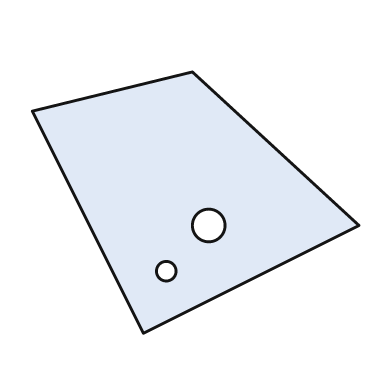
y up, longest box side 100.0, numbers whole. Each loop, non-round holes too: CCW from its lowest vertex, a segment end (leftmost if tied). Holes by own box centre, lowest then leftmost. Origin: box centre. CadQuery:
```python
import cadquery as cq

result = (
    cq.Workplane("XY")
    .moveTo(-16.0, -40.0)
    .lineTo(50.0, -7.0)
    .lineTo(-1.0, 40.0)
    .lineTo(-50.0, 28.0)
    .close()
    .moveTo(-9.0, -21.0)
    .circle(3.0)
    .moveTo(4.0, -7.0)
    .circle(5.0)
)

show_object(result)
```